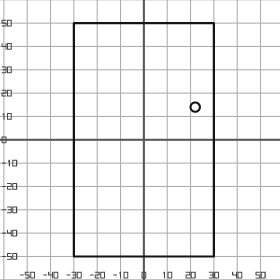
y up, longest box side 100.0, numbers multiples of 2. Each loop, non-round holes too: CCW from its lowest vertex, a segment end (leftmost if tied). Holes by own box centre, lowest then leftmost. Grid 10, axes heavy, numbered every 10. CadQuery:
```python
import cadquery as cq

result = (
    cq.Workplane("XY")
    .moveTo(-30.0, -50.0)
    .lineTo(30.0, -50.0)
    .lineTo(30.0, 50.0)
    .lineTo(-30.0, 50.0)
    .close()
    .moveTo(22.0, 14.0)
    .circle(2.0)
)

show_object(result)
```